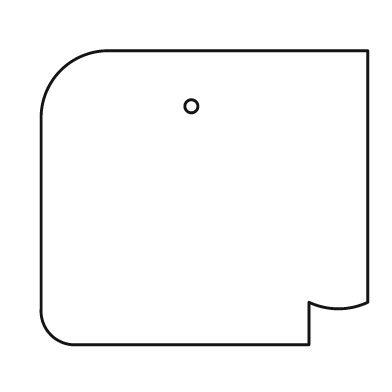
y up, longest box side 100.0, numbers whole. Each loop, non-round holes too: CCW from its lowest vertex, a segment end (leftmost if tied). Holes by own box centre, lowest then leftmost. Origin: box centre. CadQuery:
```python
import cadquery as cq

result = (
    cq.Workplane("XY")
    .moveTo(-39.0, -45.0)
    .lineTo(32.0, -45.0)
    .lineTo(32.0, -32.0)
    .threePointArc((41.0, -34.0), (50.0, -32.0))
    .lineTo(50.0, 45.0)
    .lineTo(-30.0, 45.0)
    .threePointArc((-44.0, 39.0), (-50.0, 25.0))
    .lineTo(-50.0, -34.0)
    .threePointArc((-47.0, -42.0), (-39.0, -45.0))
    .close()
    .moveTo(-4.0, 28.0)
    .circle(2.0)
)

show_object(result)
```